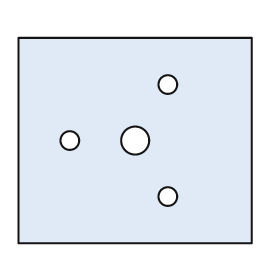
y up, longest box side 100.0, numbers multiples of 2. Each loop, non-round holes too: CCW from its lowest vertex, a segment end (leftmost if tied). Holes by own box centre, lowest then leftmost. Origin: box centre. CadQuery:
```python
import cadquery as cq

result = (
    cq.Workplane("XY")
    .moveTo(-50.0, -44.0)
    .lineTo(50.0, -44.0)
    .lineTo(50.0, 44.0)
    .lineTo(-50.0, 44.0)
    .close()
    .moveTo(14.0, -24.0)
    .circle(4.0)
    .moveTo(-28.0, 0.0)
    .circle(4.0)
    .moveTo(0.0, 0.0)
    .circle(6.0)
    .moveTo(14.0, 24.0)
    .circle(4.0)
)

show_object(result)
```